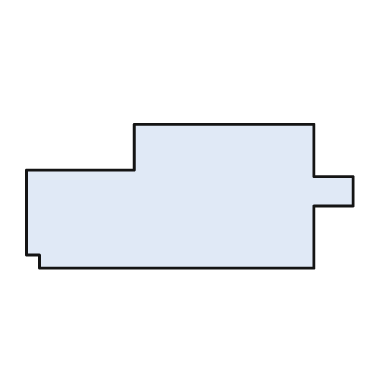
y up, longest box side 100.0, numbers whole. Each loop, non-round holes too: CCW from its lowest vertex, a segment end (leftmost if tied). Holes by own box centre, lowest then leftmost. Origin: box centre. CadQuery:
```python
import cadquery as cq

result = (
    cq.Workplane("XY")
    .moveTo(-46.0, -22.0)
    .lineTo(38.0, -22.0)
    .lineTo(38.0, -3.0)
    .lineTo(50.0, -3.0)
    .lineTo(50.0, 6.0)
    .lineTo(38.0, 6.0)
    .lineTo(38.0, 22.0)
    .lineTo(-17.0, 22.0)
    .lineTo(-17.0, 8.0)
    .lineTo(-50.0, 8.0)
    .lineTo(-50.0, -18.0)
    .lineTo(-46.0, -18.0)
    .close()
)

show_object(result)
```